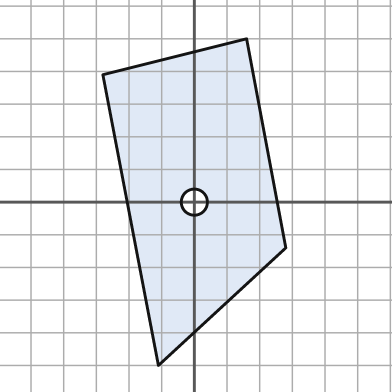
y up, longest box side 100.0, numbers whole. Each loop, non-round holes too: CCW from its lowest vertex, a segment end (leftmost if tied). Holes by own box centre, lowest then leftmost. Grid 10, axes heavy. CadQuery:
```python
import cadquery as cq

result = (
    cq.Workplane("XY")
    .moveTo(-11.0, -50.0)
    .lineTo(28.0, -14.0)
    .lineTo(16.0, 50.0)
    .lineTo(-28.0, 39.0)
    .close()
    .moveTo(0.0, 0.0)
    .circle(4.0)
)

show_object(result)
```